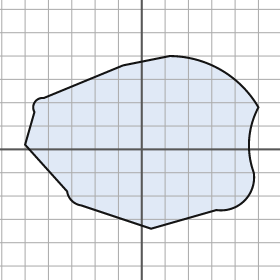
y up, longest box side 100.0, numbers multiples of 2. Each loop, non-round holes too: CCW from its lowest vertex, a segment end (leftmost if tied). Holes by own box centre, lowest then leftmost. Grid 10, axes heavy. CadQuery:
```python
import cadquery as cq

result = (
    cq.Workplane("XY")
    .moveTo(4.0, -34.0)
    .lineTo(32.0, -26.0)
    .threePointArc((44.0, -22.0), (48.0, -10.0))
    .threePointArc((46.0, 4.0), (50.0, 18.0))
    .threePointArc((34.0, 34.0), (12.0, 40.0))
    .lineTo(-8.0, 36.0)
    .lineTo(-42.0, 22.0)
    .threePointArc((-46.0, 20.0), (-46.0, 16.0))
    .lineTo(-50.0, 2.0)
    .lineTo(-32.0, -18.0)
    .threePointArc((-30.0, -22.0), (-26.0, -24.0))
    .close()
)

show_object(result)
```